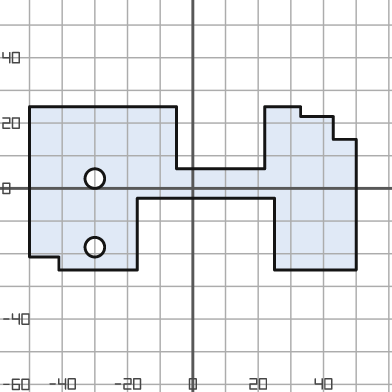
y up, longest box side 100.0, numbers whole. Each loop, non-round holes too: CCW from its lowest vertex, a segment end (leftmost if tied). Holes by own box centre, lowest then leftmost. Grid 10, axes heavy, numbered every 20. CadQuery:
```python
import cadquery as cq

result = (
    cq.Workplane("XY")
    .moveTo(-41.0, -25.0)
    .lineTo(-17.0, -25.0)
    .lineTo(-17.0, -3.0)
    .lineTo(25.0, -3.0)
    .lineTo(25.0, -25.0)
    .lineTo(50.0, -25.0)
    .lineTo(50.0, 15.0)
    .lineTo(43.0, 15.0)
    .lineTo(43.0, 22.0)
    .lineTo(33.0, 22.0)
    .lineTo(33.0, 25.0)
    .lineTo(22.0, 25.0)
    .lineTo(22.0, 6.0)
    .lineTo(-5.0, 6.0)
    .lineTo(-5.0, 25.0)
    .lineTo(-50.0, 25.0)
    .lineTo(-50.0, -21.0)
    .lineTo(-41.0, -21.0)
    .close()
    .moveTo(-30.0, -18.0)
    .circle(3.0)
    .moveTo(-30.0, 3.0)
    .circle(3.0)
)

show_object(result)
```